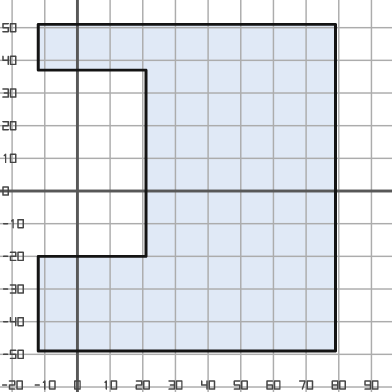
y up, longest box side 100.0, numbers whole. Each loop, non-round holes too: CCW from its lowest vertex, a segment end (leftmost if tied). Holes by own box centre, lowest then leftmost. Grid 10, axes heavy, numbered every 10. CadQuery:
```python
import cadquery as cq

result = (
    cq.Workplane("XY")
    .moveTo(-12.0, -49.0)
    .lineTo(79.0, -49.0)
    .lineTo(79.0, 51.0)
    .lineTo(-12.0, 51.0)
    .lineTo(-12.0, 37.0)
    .lineTo(21.0, 37.0)
    .lineTo(21.0, -20.0)
    .lineTo(-12.0, -20.0)
    .close()
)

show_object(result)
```